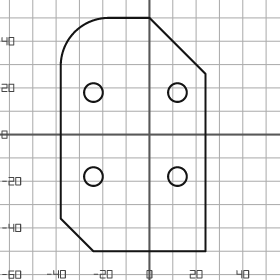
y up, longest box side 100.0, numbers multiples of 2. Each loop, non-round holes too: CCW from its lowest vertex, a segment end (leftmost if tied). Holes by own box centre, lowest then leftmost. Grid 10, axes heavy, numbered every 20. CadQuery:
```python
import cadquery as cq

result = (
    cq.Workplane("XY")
    .moveTo(-24.0, -50.0)
    .lineTo(24.0, -50.0)
    .lineTo(24.0, 26.0)
    .lineTo(0.0, 50.0)
    .lineTo(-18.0, 50.0)
    .threePointArc((-32.0, 44.0), (-38.0, 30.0))
    .lineTo(-38.0, -36.0)
    .close()
    .moveTo(-24.0, -18.0)
    .circle(4.0)
    .moveTo(12.0, -18.0)
    .circle(4.0)
    .moveTo(-24.0, 18.0)
    .circle(4.0)
    .moveTo(12.0, 18.0)
    .circle(4.0)
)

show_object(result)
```